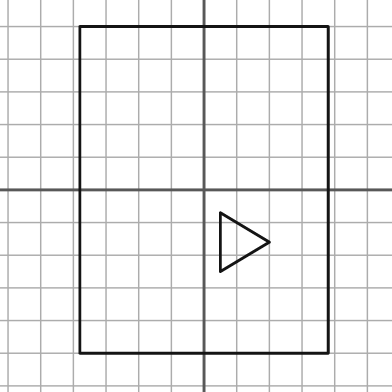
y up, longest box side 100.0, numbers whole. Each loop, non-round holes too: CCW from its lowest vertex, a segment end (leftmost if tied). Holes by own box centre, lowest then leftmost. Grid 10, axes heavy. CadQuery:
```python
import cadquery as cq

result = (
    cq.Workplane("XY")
    .moveTo(-38.0, -50.0)
    .lineTo(38.0, -50.0)
    .lineTo(38.0, 50.0)
    .lineTo(-38.0, 50.0)
    .close()
    .moveTo(5.0, -25.0)
    .lineTo(20.0, -16.0)
    .lineTo(5.0, -7.0)
    .close()
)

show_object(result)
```